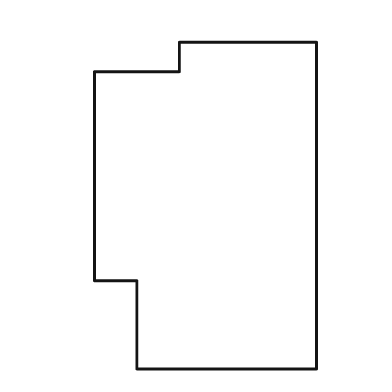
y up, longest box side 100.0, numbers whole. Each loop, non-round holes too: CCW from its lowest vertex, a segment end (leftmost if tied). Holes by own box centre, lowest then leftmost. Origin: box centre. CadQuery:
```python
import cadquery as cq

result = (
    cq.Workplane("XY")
    .moveTo(-21.0, -50.0)
    .lineTo(34.0, -50.0)
    .lineTo(34.0, 50.0)
    .lineTo(-8.0, 50.0)
    .lineTo(-8.0, 41.0)
    .lineTo(-34.0, 41.0)
    .lineTo(-34.0, -23.0)
    .lineTo(-21.0, -23.0)
    .close()
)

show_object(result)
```